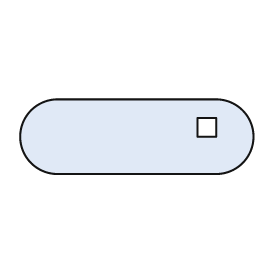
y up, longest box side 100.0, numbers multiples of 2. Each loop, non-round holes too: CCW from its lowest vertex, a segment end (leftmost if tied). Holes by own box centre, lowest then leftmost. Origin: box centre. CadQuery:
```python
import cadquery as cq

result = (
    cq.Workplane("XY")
    .moveTo(-34.0, -16.0)
    .lineTo(34.0, -16.0)
    .threePointArc((50.0, 0.0), (34.0, 16.0))
    .lineTo(-34.0, 16.0)
    .threePointArc((-50.0, 0.0), (-34.0, -16.0))
    .close()
    .moveTo(26.0, 0.0)
    .lineTo(34.0, 0.0)
    .lineTo(34.0, 8.0)
    .lineTo(26.0, 8.0)
    .close()
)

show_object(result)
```